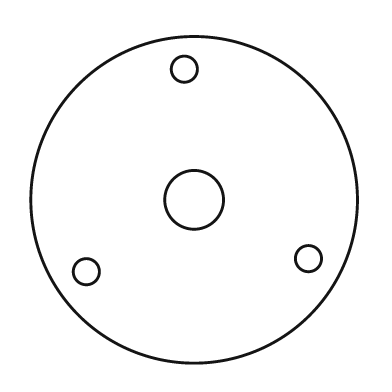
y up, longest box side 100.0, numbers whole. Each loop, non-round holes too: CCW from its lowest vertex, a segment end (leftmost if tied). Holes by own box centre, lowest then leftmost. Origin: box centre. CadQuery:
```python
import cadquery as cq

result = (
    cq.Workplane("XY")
    .moveTo(0.0, 0.0)
    .circle(50.0)
    .moveTo(-33.0, -22.0)
    .circle(4.0)
    .moveTo(35.0, -18.0)
    .circle(4.0)
    .moveTo(0.0, 0.0)
    .circle(9.0)
    .moveTo(-3.0, 40.0)
    .circle(4.0)
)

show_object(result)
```